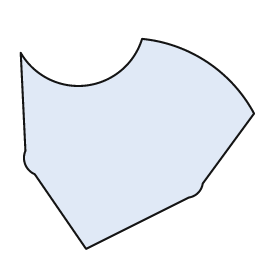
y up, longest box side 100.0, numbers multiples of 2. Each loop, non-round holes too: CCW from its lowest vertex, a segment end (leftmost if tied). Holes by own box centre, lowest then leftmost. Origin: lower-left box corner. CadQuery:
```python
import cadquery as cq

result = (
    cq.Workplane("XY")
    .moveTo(28.0, 0.0)
    .lineTo(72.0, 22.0)
    .threePointArc((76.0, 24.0), (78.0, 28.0))
    .lineTo(100.0, 58.0)
    .threePointArc((80.0, 80.0), (52.0, 90.0))
    .threePointArc((28.0, 70.0), (0.0, 84.0))
    .lineTo(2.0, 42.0)
    .threePointArc((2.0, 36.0), (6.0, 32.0))
    .close()
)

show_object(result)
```